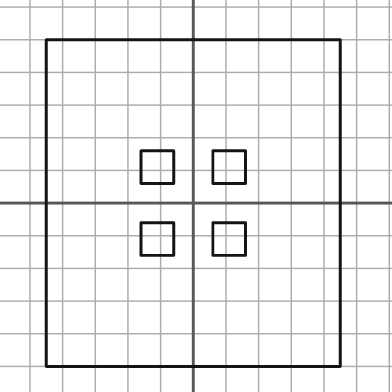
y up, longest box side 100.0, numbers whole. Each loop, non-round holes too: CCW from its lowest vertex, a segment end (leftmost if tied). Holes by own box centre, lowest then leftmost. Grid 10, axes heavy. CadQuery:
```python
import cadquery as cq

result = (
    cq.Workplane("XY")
    .moveTo(-45.0, -50.0)
    .lineTo(45.0, -50.0)
    .lineTo(45.0, 50.0)
    .lineTo(-45.0, 50.0)
    .close()
    .moveTo(-16.0, -16.0)
    .lineTo(-6.0, -16.0)
    .lineTo(-6.0, -6.0)
    .lineTo(-16.0, -6.0)
    .close()
    .moveTo(6.0, -16.0)
    .lineTo(16.0, -16.0)
    .lineTo(16.0, -6.0)
    .lineTo(6.0, -6.0)
    .close()
    .moveTo(-16.0, 6.0)
    .lineTo(-6.0, 6.0)
    .lineTo(-6.0, 16.0)
    .lineTo(-16.0, 16.0)
    .close()
    .moveTo(6.0, 6.0)
    .lineTo(16.0, 6.0)
    .lineTo(16.0, 16.0)
    .lineTo(6.0, 16.0)
    .close()
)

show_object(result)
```